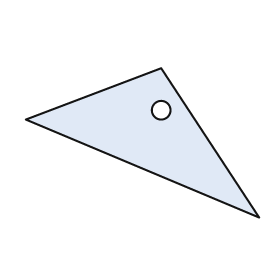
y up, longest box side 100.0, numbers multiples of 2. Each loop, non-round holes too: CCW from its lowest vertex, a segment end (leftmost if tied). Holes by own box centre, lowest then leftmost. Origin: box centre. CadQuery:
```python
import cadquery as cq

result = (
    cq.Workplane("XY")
    .moveTo(50.0, -32.0)
    .lineTo(8.0, 32.0)
    .lineTo(-50.0, 10.0)
    .close()
    .moveTo(8.0, 14.0)
    .circle(4.0)
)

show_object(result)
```